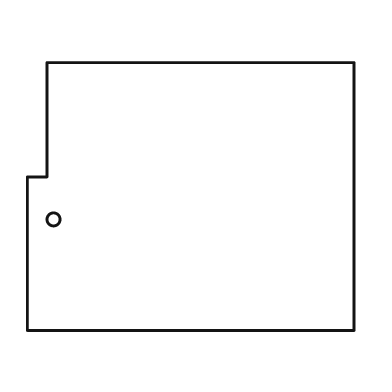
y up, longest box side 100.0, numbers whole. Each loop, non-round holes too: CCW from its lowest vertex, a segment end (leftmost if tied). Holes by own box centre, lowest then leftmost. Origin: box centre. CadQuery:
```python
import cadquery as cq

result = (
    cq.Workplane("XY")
    .moveTo(-50.0, -41.0)
    .lineTo(50.0, -41.0)
    .lineTo(50.0, 41.0)
    .lineTo(-44.0, 41.0)
    .lineTo(-44.0, 6.0)
    .lineTo(-50.0, 6.0)
    .close()
    .moveTo(-42.0, -7.0)
    .circle(2.0)
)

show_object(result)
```